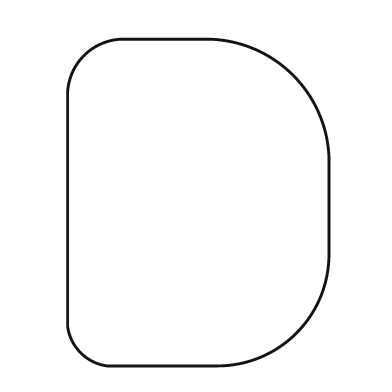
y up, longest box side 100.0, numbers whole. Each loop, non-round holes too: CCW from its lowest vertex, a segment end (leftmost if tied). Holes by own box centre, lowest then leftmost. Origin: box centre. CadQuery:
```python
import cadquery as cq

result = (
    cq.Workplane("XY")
    .moveTo(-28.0, -50.0)
    .lineTo(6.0, -50.0)
    .threePointArc((30.0, -40.0), (40.0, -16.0))
    .lineTo(40.0, 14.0)
    .threePointArc((29.0, 39.0), (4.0, 50.0))
    .lineTo(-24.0, 50.0)
    .threePointArc((-35.0, 45.0), (-40.0, 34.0))
    .lineTo(-40.0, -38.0)
    .threePointArc((-36.0, -46.0), (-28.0, -50.0))
    .close()
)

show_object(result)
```